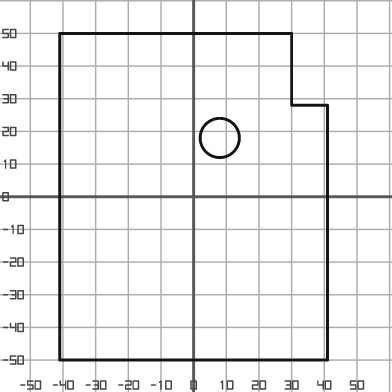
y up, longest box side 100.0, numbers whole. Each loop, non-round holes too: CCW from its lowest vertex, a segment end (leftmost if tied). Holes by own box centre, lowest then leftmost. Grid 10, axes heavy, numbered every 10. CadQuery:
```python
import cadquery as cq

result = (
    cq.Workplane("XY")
    .moveTo(-41.0, -50.0)
    .lineTo(41.0, -50.0)
    .lineTo(41.0, 28.0)
    .lineTo(30.0, 28.0)
    .lineTo(30.0, 50.0)
    .lineTo(-41.0, 50.0)
    .close()
    .moveTo(8.0, 18.0)
    .circle(6.0)
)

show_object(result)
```